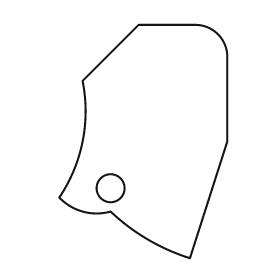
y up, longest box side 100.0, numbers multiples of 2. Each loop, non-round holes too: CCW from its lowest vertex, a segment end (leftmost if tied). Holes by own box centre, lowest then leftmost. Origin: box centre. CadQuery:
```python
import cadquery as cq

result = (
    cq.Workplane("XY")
    .moveTo(20.0, -50.0)
    .lineTo(36.0, 0.0)
    .lineTo(36.0, 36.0)
    .threePointArc((32.0, 46.0), (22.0, 50.0))
    .lineTo(-2.0, 50.0)
    .lineTo(-26.0, 26.0)
    .threePointArc((-26.0, 0.0), (-36.0, -24.0))
    .threePointArc((-26.0, -30.0), (-14.0, -30.0))
    .threePointArc((2.0, -42.0), (20.0, -50.0))
    .close()
    .moveTo(-14.0, -20.0)
    .circle(6.0)
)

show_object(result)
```